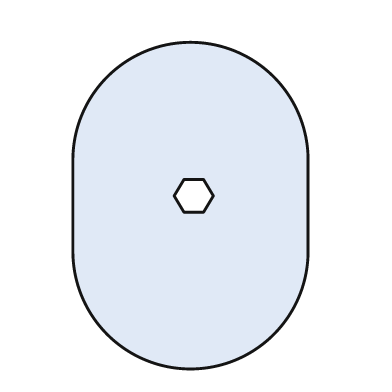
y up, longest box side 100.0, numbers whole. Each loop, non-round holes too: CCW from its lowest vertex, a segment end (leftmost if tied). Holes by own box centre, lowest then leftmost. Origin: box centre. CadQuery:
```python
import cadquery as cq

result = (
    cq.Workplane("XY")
    .moveTo(-36.0, -14.0)
    .threePointArc((0.0, -50.0), (36.0, -14.0))
    .lineTo(36.0, 14.0)
    .threePointArc((0.0, 50.0), (-36.0, 14.0))
    .close()
    .moveTo(-2.0, -2.0)
    .lineTo(4.0, -2.0)
    .lineTo(7.0, 3.0)
    .lineTo(4.0, 8.0)
    .lineTo(-2.0, 8.0)
    .lineTo(-5.0, 3.0)
    .close()
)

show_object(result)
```